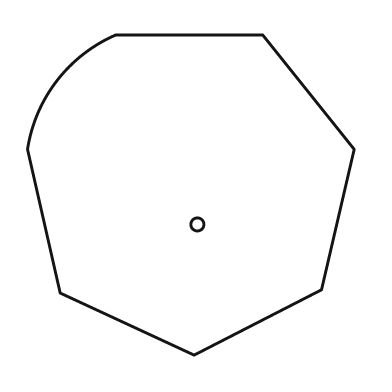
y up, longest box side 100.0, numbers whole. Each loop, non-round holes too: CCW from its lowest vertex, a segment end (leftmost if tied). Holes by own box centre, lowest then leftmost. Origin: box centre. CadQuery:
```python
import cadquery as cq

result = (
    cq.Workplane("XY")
    .moveTo(1.0, -49.0)
    .lineTo(40.0, -29.0)
    .lineTo(50.0, 14.0)
    .lineTo(22.0, 49.0)
    .lineTo(-23.0, 49.0)
    .threePointArc((-41.0, 35.0), (-50.0, 14.0))
    .lineTo(-40.0, -30.0)
    .close()
    .moveTo(2.0, -9.0)
    .circle(2.0)
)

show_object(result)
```